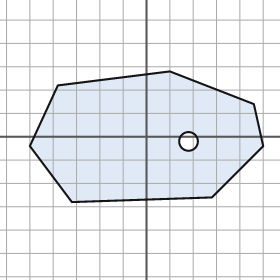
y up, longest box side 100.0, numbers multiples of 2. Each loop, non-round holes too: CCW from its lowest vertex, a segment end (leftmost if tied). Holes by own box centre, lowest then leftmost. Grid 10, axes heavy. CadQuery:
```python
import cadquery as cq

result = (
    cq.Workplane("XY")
    .moveTo(-32.0, -28.0)
    .lineTo(28.0, -26.0)
    .lineTo(50.0, -4.0)
    .lineTo(46.0, 14.0)
    .lineTo(10.0, 28.0)
    .lineTo(-38.0, 22.0)
    .lineTo(-50.0, -4.0)
    .close()
    .moveTo(18.0, -2.0)
    .circle(4.0)
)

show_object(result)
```